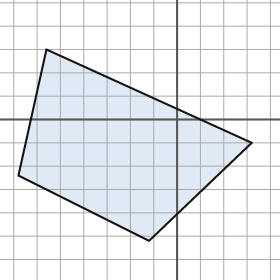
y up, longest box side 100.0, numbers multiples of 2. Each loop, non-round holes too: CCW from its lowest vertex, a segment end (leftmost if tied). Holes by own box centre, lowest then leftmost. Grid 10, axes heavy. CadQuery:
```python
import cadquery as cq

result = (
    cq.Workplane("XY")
    .moveTo(-12.0, -52.0)
    .lineTo(32.0, -10.0)
    .lineTo(-56.0, 30.0)
    .lineTo(-68.0, -24.0)
    .close()
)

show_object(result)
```